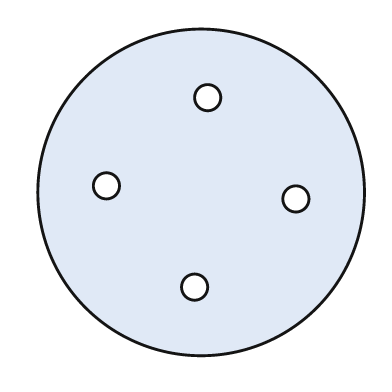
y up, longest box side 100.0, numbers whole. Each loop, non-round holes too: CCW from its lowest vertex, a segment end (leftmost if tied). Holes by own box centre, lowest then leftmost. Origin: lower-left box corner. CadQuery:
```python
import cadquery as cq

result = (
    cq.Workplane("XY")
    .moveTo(50.0, 50.0)
    .circle(50.0)
    .moveTo(48.0, 21.0)
    .circle(4.0)
    .moveTo(79.0, 48.0)
    .circle(4.0)
    .moveTo(21.0, 52.0)
    .circle(4.0)
    .moveTo(52.0, 79.0)
    .circle(4.0)
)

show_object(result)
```